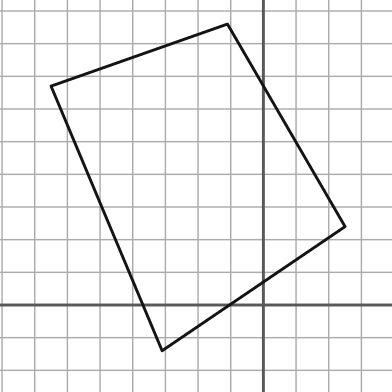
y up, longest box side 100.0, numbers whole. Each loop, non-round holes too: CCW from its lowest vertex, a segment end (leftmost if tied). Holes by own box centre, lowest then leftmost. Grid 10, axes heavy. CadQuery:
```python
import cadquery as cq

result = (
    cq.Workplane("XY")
    .moveTo(-31.0, -14.0)
    .lineTo(25.0, 24.0)
    .lineTo(-11.0, 86.0)
    .lineTo(-65.0, 67.0)
    .close()
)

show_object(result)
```